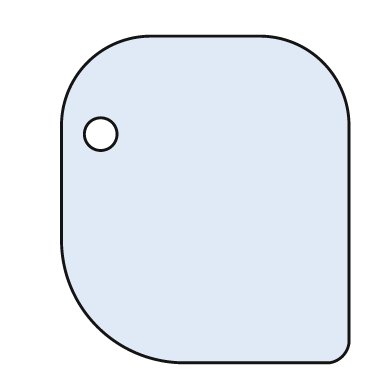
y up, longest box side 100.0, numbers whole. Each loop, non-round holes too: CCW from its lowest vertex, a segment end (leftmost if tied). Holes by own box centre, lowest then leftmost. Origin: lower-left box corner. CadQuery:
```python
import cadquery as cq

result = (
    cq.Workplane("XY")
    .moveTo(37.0, 0.0)
    .lineTo(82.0, 0.0)
    .threePointArc((86.0, 2.0), (88.0, 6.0))
    .lineTo(88.0, 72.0)
    .threePointArc((80.0, 92.0), (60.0, 100.0))
    .lineTo(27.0, 100.0)
    .threePointArc((8.0, 92.0), (0.0, 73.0))
    .lineTo(0.0, 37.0)
    .threePointArc((11.0, 11.0), (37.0, 0.0))
    .close()
    .moveTo(12.0, 70.0)
    .circle(5.0)
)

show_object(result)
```